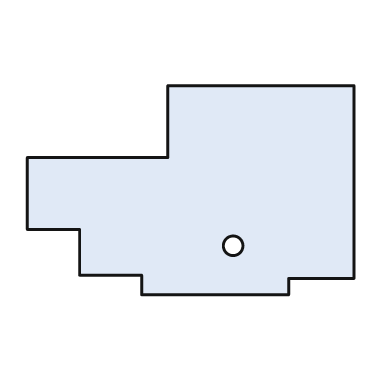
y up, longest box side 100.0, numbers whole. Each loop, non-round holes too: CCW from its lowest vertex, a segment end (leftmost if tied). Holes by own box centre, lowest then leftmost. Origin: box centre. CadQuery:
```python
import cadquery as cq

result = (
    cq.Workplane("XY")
    .moveTo(-15.0, -32.0)
    .lineTo(30.0, -32.0)
    .lineTo(30.0, -27.0)
    .lineTo(50.0, -27.0)
    .lineTo(50.0, 32.0)
    .lineTo(-7.0, 32.0)
    .lineTo(-7.0, 10.0)
    .lineTo(-50.0, 10.0)
    .lineTo(-50.0, -12.0)
    .lineTo(-34.0, -12.0)
    .lineTo(-34.0, -26.0)
    .lineTo(-15.0, -26.0)
    .close()
    .moveTo(13.0, -17.0)
    .circle(3.0)
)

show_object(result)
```